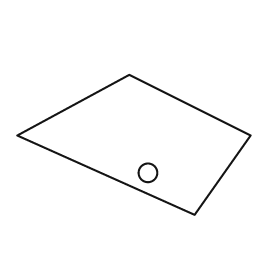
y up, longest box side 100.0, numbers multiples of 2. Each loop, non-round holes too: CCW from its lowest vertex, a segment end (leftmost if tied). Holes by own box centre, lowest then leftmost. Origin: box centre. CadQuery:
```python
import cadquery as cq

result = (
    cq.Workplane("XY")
    .moveTo(26.0, -30.0)
    .lineTo(50.0, 4.0)
    .lineTo(-2.0, 30.0)
    .lineTo(-50.0, 4.0)
    .close()
    .moveTo(6.0, -12.0)
    .circle(4.0)
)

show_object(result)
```